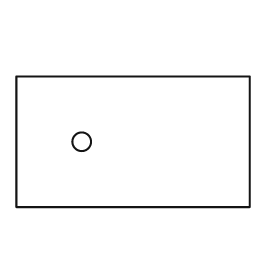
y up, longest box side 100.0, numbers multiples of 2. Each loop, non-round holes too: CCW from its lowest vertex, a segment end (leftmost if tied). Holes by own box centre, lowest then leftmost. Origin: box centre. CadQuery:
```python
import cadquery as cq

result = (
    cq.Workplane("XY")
    .moveTo(-50.0, -28.0)
    .lineTo(50.0, -28.0)
    .lineTo(50.0, 28.0)
    .lineTo(-50.0, 28.0)
    .close()
    .moveTo(-22.0, 0.0)
    .circle(4.0)
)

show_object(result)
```